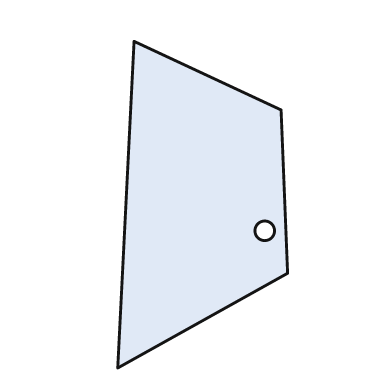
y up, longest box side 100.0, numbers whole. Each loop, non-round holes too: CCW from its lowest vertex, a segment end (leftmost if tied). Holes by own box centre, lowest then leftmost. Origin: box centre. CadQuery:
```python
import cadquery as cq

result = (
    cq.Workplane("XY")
    .moveTo(-26.0, -50.0)
    .lineTo(26.0, -21.0)
    .lineTo(24.0, 29.0)
    .lineTo(-21.0, 50.0)
    .close()
    .moveTo(19.0, -8.0)
    .circle(3.0)
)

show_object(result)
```